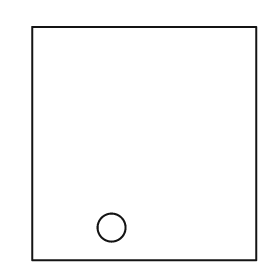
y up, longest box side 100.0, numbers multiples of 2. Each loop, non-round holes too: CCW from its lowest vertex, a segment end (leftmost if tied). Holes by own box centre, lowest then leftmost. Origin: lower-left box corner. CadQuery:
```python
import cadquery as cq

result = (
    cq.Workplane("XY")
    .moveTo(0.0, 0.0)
    .lineTo(96.0, 0.0)
    .lineTo(96.0, 100.0)
    .lineTo(0.0, 100.0)
    .close()
    .moveTo(34.0, 14.0)
    .circle(6.0)
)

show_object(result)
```